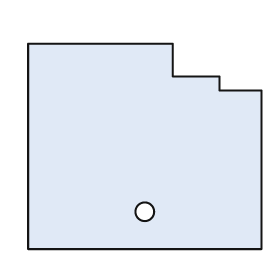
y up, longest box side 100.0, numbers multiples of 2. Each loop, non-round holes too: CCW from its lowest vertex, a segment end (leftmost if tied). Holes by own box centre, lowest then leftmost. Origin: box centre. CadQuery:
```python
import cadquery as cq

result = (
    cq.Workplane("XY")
    .moveTo(-50.0, -44.0)
    .lineTo(50.0, -44.0)
    .lineTo(50.0, 24.0)
    .lineTo(32.0, 24.0)
    .lineTo(32.0, 30.0)
    .lineTo(12.0, 30.0)
    .lineTo(12.0, 44.0)
    .lineTo(-50.0, 44.0)
    .close()
    .moveTo(0.0, -28.0)
    .circle(4.0)
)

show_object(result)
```